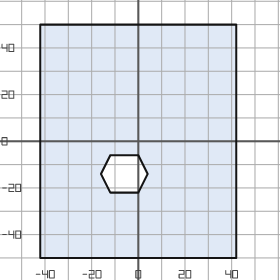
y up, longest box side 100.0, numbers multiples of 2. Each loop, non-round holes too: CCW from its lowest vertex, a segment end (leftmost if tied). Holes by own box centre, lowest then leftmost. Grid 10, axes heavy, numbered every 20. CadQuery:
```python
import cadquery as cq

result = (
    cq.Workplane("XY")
    .moveTo(-42.0, -50.0)
    .lineTo(42.0, -50.0)
    .lineTo(42.0, 50.0)
    .lineTo(-42.0, 50.0)
    .close()
    .moveTo(-12.0, -22.0)
    .lineTo(0.0, -22.0)
    .lineTo(4.0, -14.0)
    .lineTo(0.0, -6.0)
    .lineTo(-12.0, -6.0)
    .lineTo(-16.0, -14.0)
    .close()
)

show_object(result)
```